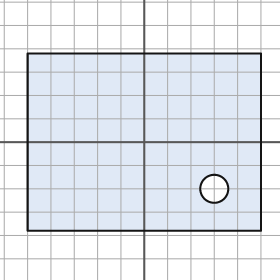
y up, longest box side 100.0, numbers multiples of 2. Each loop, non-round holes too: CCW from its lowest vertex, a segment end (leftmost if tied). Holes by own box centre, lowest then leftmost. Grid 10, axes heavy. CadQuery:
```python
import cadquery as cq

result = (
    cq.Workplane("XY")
    .moveTo(-50.0, -38.0)
    .lineTo(50.0, -38.0)
    .lineTo(50.0, 38.0)
    .lineTo(-50.0, 38.0)
    .close()
    .moveTo(30.0, -20.0)
    .circle(6.0)
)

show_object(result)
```